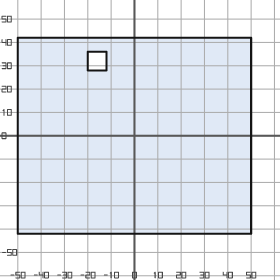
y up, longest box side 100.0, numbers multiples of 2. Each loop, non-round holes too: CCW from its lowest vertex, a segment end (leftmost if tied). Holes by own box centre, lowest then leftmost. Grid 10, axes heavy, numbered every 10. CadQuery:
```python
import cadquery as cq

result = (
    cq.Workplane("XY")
    .moveTo(-50.0, -42.0)
    .lineTo(50.0, -42.0)
    .lineTo(50.0, 42.0)
    .lineTo(-50.0, 42.0)
    .close()
    .moveTo(-20.0, 28.0)
    .lineTo(-12.0, 28.0)
    .lineTo(-12.0, 36.0)
    .lineTo(-20.0, 36.0)
    .close()
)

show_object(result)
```